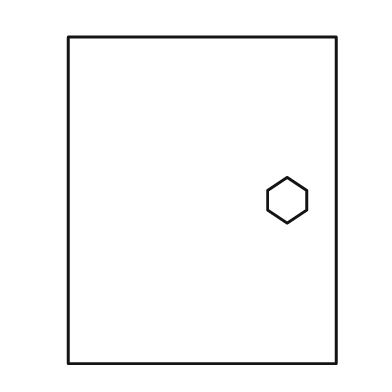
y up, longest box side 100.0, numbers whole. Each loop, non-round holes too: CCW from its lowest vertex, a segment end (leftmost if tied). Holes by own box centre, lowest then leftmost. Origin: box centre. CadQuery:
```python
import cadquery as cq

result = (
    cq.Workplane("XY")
    .moveTo(-41.0, -50.0)
    .lineTo(41.0, -50.0)
    .lineTo(41.0, 50.0)
    .lineTo(-41.0, 50.0)
    .close()
    .moveTo(26.0, -7.0)
    .lineTo(32.0, -3.0)
    .lineTo(32.0, 3.0)
    .lineTo(26.0, 7.0)
    .lineTo(20.0, 3.0)
    .lineTo(20.0, -3.0)
    .close()
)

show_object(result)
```